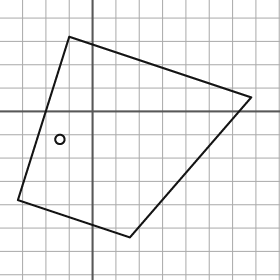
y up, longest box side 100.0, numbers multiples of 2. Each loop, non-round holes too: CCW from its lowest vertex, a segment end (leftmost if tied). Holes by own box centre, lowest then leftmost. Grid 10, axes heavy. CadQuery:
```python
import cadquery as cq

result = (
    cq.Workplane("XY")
    .moveTo(16.0, -54.0)
    .lineTo(68.0, 6.0)
    .lineTo(-10.0, 32.0)
    .lineTo(-32.0, -38.0)
    .close()
    .moveTo(-14.0, -12.0)
    .circle(2.0)
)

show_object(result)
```